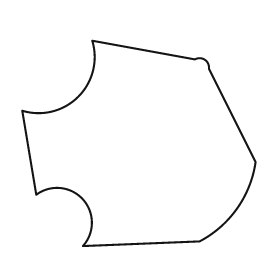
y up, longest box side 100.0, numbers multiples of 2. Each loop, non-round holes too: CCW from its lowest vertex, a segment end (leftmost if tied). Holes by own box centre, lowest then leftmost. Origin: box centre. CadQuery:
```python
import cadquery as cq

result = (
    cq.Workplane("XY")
    .moveTo(-24.0, -44.0)
    .lineTo(26.0, -42.0)
    .threePointArc((42.0, -28.0), (50.0, -8.0))
    .lineTo(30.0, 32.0)
    .threePointArc((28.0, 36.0), (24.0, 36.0))
    .lineTo(-20.0, 44.0)
    .threePointArc((-26.0, 20.0), (-50.0, 14.0))
    .lineTo(-44.0, -22.0)
    .threePointArc((-24.0, -24.0), (-24.0, -44.0))
    .close()
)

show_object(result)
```